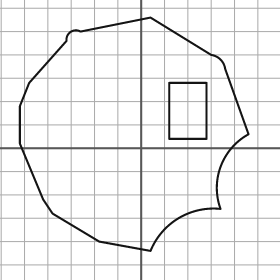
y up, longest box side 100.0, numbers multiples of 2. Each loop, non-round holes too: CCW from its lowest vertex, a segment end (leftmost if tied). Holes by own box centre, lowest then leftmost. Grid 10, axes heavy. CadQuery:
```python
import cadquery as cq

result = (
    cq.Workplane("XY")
    .moveTo(4.0, -44.0)
    .threePointArc((16.0, -30.0), (34.0, -26.0))
    .threePointArc((34.0, -8.0), (46.0, 6.0))
    .lineTo(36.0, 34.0)
    .threePointArc((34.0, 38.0), (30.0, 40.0))
    .lineTo(4.0, 56.0)
    .lineTo(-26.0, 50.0)
    .threePointArc((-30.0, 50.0), (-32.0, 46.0))
    .lineTo(-48.0, 28.0)
    .lineTo(-52.0, 18.0)
    .lineTo(-52.0, 2.0)
    .lineTo(-42.0, -22.0)
    .lineTo(-38.0, -28.0)
    .lineTo(-18.0, -40.0)
    .close()
    .moveTo(12.0, 4.0)
    .lineTo(28.0, 4.0)
    .lineTo(28.0, 28.0)
    .lineTo(12.0, 28.0)
    .close()
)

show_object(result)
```